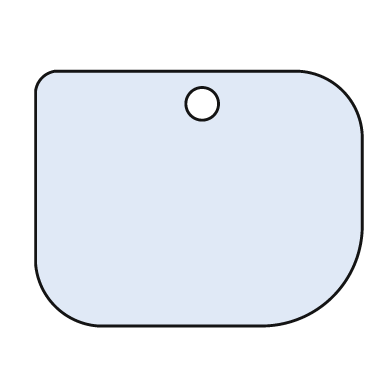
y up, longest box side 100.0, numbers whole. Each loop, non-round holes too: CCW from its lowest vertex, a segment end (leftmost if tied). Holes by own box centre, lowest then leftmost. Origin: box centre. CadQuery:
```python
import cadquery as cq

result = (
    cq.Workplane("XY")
    .moveTo(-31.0, -39.0)
    .lineTo(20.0, -39.0)
    .threePointArc((41.0, -30.0), (50.0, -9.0))
    .lineTo(50.0, 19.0)
    .threePointArc((44.0, 33.0), (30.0, 39.0))
    .lineTo(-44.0, 39.0)
    .threePointArc((-48.0, 37.0), (-50.0, 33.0))
    .lineTo(-50.0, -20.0)
    .threePointArc((-44.0, -33.0), (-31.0, -39.0))
    .close()
    .moveTo(1.0, 29.0)
    .circle(5.0)
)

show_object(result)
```